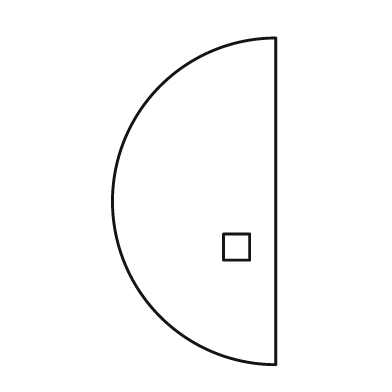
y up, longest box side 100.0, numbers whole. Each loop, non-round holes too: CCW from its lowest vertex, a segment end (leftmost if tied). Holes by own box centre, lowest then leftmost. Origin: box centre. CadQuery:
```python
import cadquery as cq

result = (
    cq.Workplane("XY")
    .moveTo(25.0, -50.0)
    .lineTo(25.0, 50.0)
    .threePointArc((-25.0, 0.0), (25.0, -50.0))
    .close()
    .moveTo(9.0, -18.0)
    .lineTo(17.0, -18.0)
    .lineTo(17.0, -10.0)
    .lineTo(9.0, -10.0)
    .close()
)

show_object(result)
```